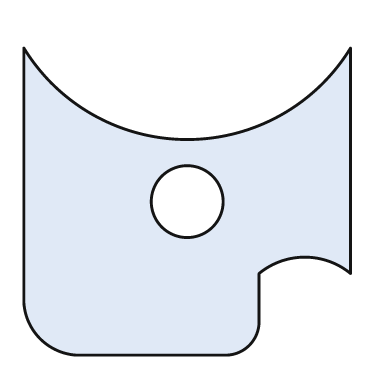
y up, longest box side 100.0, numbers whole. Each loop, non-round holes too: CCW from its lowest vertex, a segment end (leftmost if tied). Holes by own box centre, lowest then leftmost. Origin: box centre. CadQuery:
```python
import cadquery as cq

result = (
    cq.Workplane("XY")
    .moveTo(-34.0, -47.0)
    .lineTo(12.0, -47.0)
    .threePointArc((19.0, -44.0), (22.0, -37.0))
    .lineTo(22.0, -22.0)
    .threePointArc((36.0, -17.0), (50.0, -22.0))
    .lineTo(50.0, 47.0)
    .threePointArc((0.0, 19.0), (-50.0, 47.0))
    .lineTo(-50.0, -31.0)
    .threePointArc((-45.0, -42.0), (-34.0, -47.0))
    .close()
    .moveTo(0.0, 0.0)
    .circle(11.0)
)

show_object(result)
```